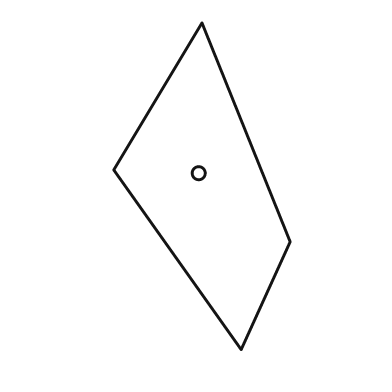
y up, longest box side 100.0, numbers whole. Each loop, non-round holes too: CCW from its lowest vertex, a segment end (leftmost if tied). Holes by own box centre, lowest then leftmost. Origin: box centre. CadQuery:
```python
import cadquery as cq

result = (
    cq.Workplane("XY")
    .moveTo(12.0, -50.0)
    .lineTo(27.0, -17.0)
    .lineTo(0.0, 50.0)
    .lineTo(-27.0, 5.0)
    .close()
    .moveTo(-1.0, 4.0)
    .circle(2.0)
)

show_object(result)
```